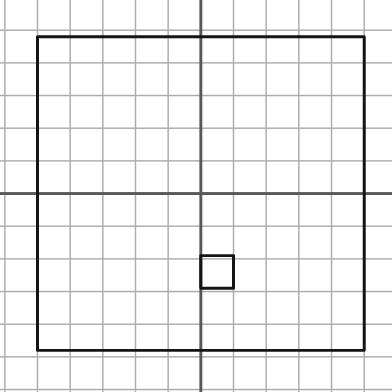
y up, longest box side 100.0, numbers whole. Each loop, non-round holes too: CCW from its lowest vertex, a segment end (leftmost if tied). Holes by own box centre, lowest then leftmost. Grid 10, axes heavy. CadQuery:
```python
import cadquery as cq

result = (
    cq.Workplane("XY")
    .moveTo(-50.0, -48.0)
    .lineTo(50.0, -48.0)
    .lineTo(50.0, 48.0)
    .lineTo(-50.0, 48.0)
    .close()
    .moveTo(0.0, -29.0)
    .lineTo(10.0, -29.0)
    .lineTo(10.0, -19.0)
    .lineTo(0.0, -19.0)
    .close()
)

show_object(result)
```